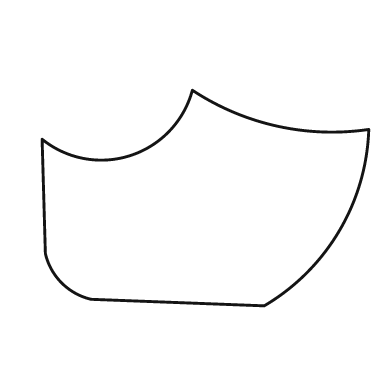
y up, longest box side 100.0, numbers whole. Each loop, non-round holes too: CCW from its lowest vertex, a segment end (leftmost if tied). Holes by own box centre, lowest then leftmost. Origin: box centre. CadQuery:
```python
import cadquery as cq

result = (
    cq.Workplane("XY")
    .moveTo(18.0, -33.0)
    .threePointArc((41.0, -10.0), (50.0, 21.0))
    .threePointArc((22.0, 22.0), (-4.0, 33.0))
    .threePointArc((-23.0, 13.0), (-50.0, 18.0))
    .lineTo(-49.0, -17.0)
    .threePointArc((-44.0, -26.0), (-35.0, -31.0))
    .close()
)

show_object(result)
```